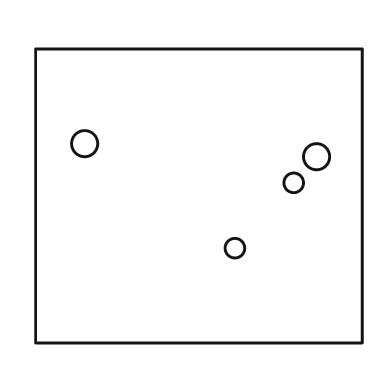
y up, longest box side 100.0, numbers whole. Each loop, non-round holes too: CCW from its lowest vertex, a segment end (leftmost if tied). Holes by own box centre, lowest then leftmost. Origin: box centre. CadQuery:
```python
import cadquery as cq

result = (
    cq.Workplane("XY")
    .moveTo(-50.0, -45.0)
    .lineTo(50.0, -45.0)
    .lineTo(50.0, 45.0)
    .lineTo(-50.0, 45.0)
    .close()
    .moveTo(11.0, -16.0)
    .circle(3.0)
    .moveTo(29.0, 4.0)
    .circle(3.0)
    .moveTo(36.0, 12.0)
    .circle(4.0)
    .moveTo(-35.0, 16.0)
    .circle(4.0)
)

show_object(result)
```